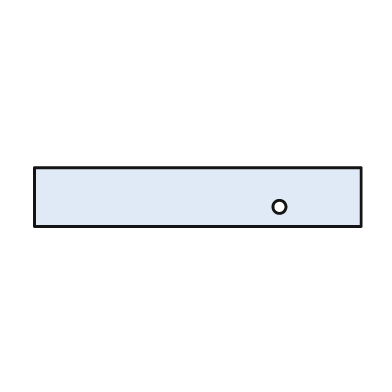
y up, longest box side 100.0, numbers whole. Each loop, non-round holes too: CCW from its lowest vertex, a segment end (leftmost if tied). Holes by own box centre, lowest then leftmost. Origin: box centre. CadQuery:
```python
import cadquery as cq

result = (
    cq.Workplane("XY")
    .moveTo(-50.0, -9.0)
    .lineTo(50.0, -9.0)
    .lineTo(50.0, 9.0)
    .lineTo(-50.0, 9.0)
    .close()
    .moveTo(25.0, -3.0)
    .circle(2.0)
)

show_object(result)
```